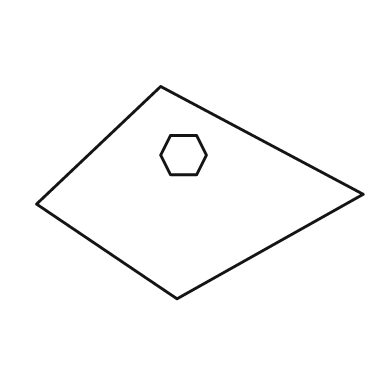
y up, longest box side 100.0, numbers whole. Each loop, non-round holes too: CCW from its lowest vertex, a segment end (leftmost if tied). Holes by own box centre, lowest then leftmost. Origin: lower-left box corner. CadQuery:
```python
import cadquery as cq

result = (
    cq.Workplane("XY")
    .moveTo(43.0, 0.0)
    .lineTo(100.0, 32.0)
    .lineTo(38.0, 65.0)
    .lineTo(0.0, 29.0)
    .close()
    .moveTo(41.0, 38.0)
    .lineTo(49.0, 38.0)
    .lineTo(52.0, 44.0)
    .lineTo(49.0, 50.0)
    .lineTo(41.0, 50.0)
    .lineTo(38.0, 44.0)
    .close()
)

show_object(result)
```